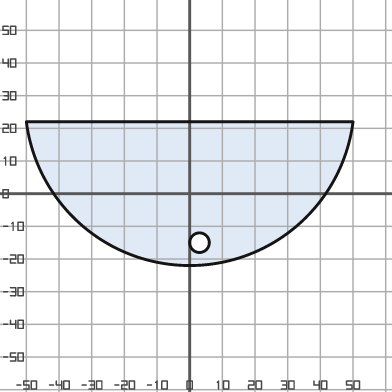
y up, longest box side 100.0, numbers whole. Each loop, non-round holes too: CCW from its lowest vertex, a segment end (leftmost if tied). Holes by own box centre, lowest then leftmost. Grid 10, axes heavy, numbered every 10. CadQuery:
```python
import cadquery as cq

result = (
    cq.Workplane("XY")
    .moveTo(-50.0, 22.0)
    .threePointArc((0.0, -22.0), (50.0, 22.0))
    .close()
    .moveTo(3.0, -15.0)
    .circle(3.0)
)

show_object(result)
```